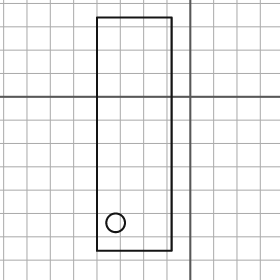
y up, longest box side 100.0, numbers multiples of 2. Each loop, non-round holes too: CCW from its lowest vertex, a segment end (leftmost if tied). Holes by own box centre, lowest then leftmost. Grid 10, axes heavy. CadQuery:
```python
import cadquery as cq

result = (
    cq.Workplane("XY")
    .moveTo(-40.0, -66.0)
    .lineTo(-8.0, -66.0)
    .lineTo(-8.0, 34.0)
    .lineTo(-40.0, 34.0)
    .close()
    .moveTo(-32.0, -54.0)
    .circle(4.0)
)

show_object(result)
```